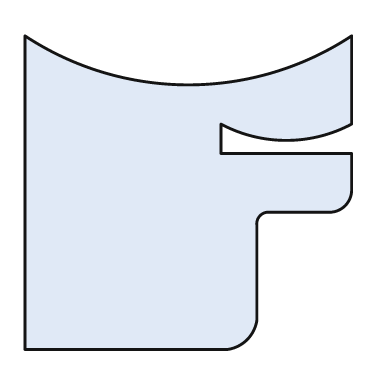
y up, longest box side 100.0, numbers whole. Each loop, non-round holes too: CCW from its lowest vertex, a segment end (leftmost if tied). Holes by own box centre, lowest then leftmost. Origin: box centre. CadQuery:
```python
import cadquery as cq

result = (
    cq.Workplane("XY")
    .moveTo(-50.0, -48.0)
    .lineTo(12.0, -48.0)
    .threePointArc((18.0, -45.0), (21.0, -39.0))
    .lineTo(21.0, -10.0)
    .threePointArc((22.0, -7.0), (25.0, -6.0))
    .lineTo(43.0, -6.0)
    .threePointArc((48.0, -4.0), (50.0, 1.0))
    .lineTo(50.0, 12.0)
    .lineTo(10.0, 12.0)
    .lineTo(10.0, 21.0)
    .threePointArc((30.0, 16.0), (50.0, 21.0))
    .lineTo(50.0, 48.0)
    .threePointArc((0.0, 33.0), (-50.0, 48.0))
    .close()
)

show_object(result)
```